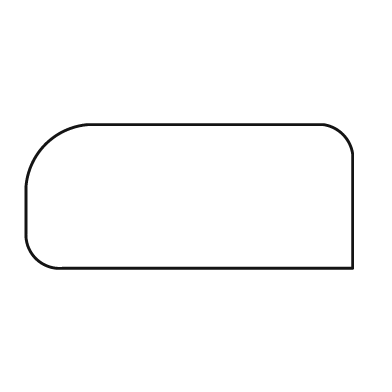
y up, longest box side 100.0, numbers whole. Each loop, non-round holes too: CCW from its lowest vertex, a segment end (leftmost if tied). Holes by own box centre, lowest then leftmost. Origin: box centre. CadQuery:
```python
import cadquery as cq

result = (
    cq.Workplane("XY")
    .moveTo(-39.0, -22.0)
    .lineTo(50.0, -22.0)
    .lineTo(50.0, 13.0)
    .threePointArc((47.0, 19.0), (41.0, 22.0))
    .lineTo(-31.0, 22.0)
    .threePointArc((-44.0, 16.0), (-50.0, 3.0))
    .lineTo(-50.0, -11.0)
    .threePointArc((-47.0, -19.0), (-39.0, -22.0))
    .close()
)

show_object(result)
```